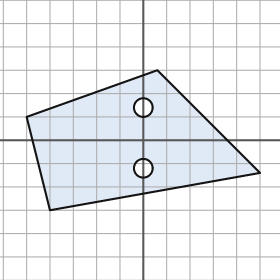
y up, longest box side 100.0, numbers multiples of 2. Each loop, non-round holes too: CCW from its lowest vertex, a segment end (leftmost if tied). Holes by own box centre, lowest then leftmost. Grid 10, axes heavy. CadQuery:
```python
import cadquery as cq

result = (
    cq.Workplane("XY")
    .moveTo(-40.0, -30.0)
    .lineTo(50.0, -14.0)
    .lineTo(6.0, 30.0)
    .lineTo(-50.0, 10.0)
    .close()
    .moveTo(0.0, -12.0)
    .circle(4.0)
    .moveTo(0.0, 14.0)
    .circle(4.0)
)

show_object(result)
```